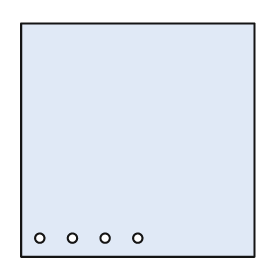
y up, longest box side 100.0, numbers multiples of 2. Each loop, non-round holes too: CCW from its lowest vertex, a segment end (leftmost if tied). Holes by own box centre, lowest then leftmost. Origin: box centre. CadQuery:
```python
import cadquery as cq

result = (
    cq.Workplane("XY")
    .moveTo(-50.0, -50.0)
    .lineTo(50.0, -50.0)
    .lineTo(50.0, 50.0)
    .lineTo(-50.0, 50.0)
    .close()
    .moveTo(-42.0, -42.0)
    .circle(2.0)
    .moveTo(-28.0, -42.0)
    .circle(2.0)
    .moveTo(-14.0, -42.0)
    .circle(2.0)
    .moveTo(0.0, -42.0)
    .circle(2.0)
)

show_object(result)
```